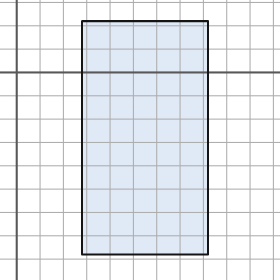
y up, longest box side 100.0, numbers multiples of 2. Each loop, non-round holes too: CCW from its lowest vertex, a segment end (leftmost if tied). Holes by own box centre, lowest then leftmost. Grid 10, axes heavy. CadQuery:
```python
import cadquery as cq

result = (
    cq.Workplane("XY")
    .moveTo(28.0, -78.0)
    .lineTo(82.0, -78.0)
    .lineTo(82.0, 22.0)
    .lineTo(28.0, 22.0)
    .close()
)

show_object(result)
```